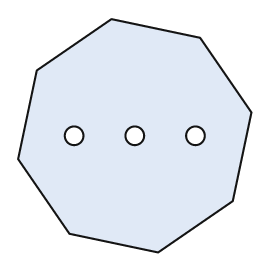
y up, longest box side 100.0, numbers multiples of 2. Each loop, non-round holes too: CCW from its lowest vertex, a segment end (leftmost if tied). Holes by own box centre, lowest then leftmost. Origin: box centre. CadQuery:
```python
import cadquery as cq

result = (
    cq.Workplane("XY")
    .moveTo(10.0, -50.0)
    .lineTo(42.0, -28.0)
    .lineTo(50.0, 10.0)
    .lineTo(28.0, 42.0)
    .lineTo(-10.0, 50.0)
    .lineTo(-42.0, 28.0)
    .lineTo(-50.0, -10.0)
    .lineTo(-28.0, -42.0)
    .close()
    .moveTo(-26.0, 0.0)
    .circle(4.0)
    .moveTo(0.0, 0.0)
    .circle(4.0)
    .moveTo(26.0, 0.0)
    .circle(4.0)
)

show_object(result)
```